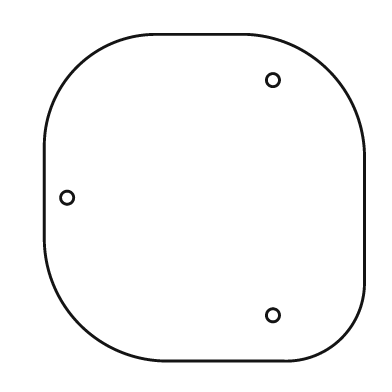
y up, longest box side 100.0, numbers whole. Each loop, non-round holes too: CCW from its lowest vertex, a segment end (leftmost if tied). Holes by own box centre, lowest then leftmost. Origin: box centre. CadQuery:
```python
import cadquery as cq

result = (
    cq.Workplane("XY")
    .moveTo(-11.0, -50.0)
    .lineTo(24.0, -50.0)
    .threePointArc((42.0, -43.0), (49.0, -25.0))
    .lineTo(49.0, 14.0)
    .threePointArc((38.0, 39.0), (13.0, 50.0))
    .lineTo(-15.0, 50.0)
    .threePointArc((-39.0, 40.0), (-49.0, 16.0))
    .lineTo(-49.0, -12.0)
    .threePointArc((-38.0, -39.0), (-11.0, -50.0))
    .close()
    .moveTo(21.0, -36.0)
    .circle(2.0)
    .moveTo(-42.0, 0.0)
    .circle(2.0)
    .moveTo(21.0, 36.0)
    .circle(2.0)
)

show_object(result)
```